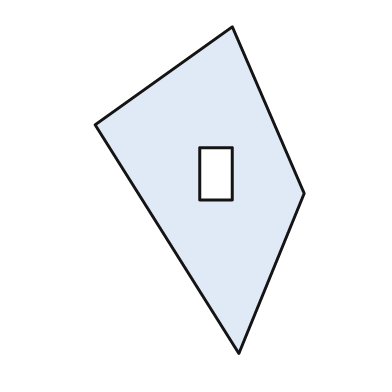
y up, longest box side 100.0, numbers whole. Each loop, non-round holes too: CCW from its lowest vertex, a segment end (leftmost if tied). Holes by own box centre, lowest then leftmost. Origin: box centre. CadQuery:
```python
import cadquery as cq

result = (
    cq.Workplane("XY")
    .moveTo(12.0, -50.0)
    .lineTo(32.0, -1.0)
    .lineTo(10.0, 50.0)
    .lineTo(-32.0, 20.0)
    .close()
    .moveTo(0.0, -3.0)
    .lineTo(10.0, -3.0)
    .lineTo(10.0, 13.0)
    .lineTo(0.0, 13.0)
    .close()
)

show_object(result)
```